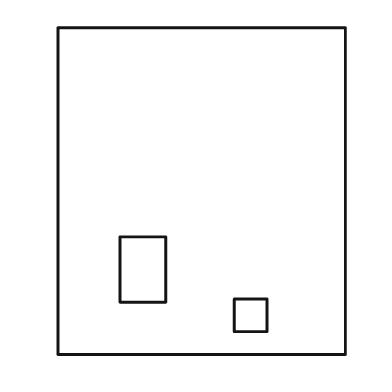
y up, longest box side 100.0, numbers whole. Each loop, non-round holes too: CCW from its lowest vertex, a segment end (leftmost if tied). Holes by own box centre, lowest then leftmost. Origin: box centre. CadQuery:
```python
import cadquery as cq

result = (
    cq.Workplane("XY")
    .moveTo(-44.0, -50.0)
    .lineTo(44.0, -50.0)
    .lineTo(44.0, 50.0)
    .lineTo(-44.0, 50.0)
    .close()
    .moveTo(10.0, -43.0)
    .lineTo(20.0, -43.0)
    .lineTo(20.0, -33.0)
    .lineTo(10.0, -33.0)
    .close()
    .moveTo(-25.0, -34.0)
    .lineTo(-11.0, -34.0)
    .lineTo(-11.0, -14.0)
    .lineTo(-25.0, -14.0)
    .close()
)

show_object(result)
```